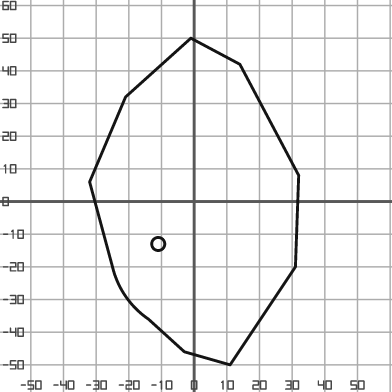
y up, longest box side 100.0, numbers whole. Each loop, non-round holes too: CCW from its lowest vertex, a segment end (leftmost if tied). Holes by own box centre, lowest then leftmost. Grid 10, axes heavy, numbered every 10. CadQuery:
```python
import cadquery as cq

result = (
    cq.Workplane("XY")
    .moveTo(11.0, -50.0)
    .lineTo(31.0, -20.0)
    .lineTo(32.0, 8.0)
    .lineTo(14.0, 42.0)
    .lineTo(-1.0, 50.0)
    .lineTo(-21.0, 32.0)
    .lineTo(-32.0, 6.0)
    .lineTo(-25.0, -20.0)
    .threePointArc((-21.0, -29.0), (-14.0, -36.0))
    .lineTo(-3.0, -46.0)
    .close()
    .moveTo(-11.0, -13.0)
    .circle(2.0)
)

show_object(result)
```